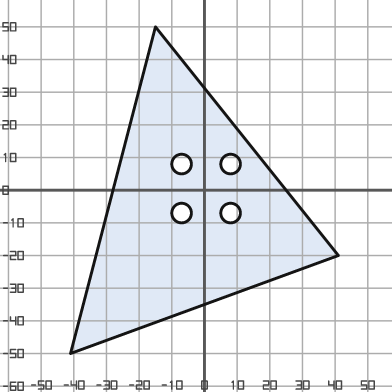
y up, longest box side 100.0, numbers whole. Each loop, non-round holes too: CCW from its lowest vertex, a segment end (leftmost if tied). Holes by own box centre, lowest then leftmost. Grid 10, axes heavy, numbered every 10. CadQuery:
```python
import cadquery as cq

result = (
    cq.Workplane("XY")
    .moveTo(-41.0, -50.0)
    .lineTo(41.0, -20.0)
    .lineTo(-15.0, 50.0)
    .close()
    .moveTo(-7.0, -7.0)
    .circle(3.0)
    .moveTo(8.0, -7.0)
    .circle(3.0)
    .moveTo(-7.0, 8.0)
    .circle(3.0)
    .moveTo(8.0, 8.0)
    .circle(3.0)
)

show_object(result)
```